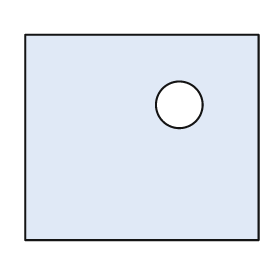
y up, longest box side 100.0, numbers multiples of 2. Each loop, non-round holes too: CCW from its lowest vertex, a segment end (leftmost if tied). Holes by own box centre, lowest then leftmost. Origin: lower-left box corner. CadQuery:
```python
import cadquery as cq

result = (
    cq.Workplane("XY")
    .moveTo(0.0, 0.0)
    .lineTo(100.0, 0.0)
    .lineTo(100.0, 88.0)
    .lineTo(0.0, 88.0)
    .close()
    .moveTo(66.0, 58.0)
    .circle(10.0)
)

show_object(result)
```